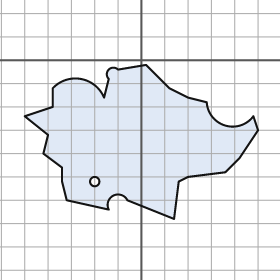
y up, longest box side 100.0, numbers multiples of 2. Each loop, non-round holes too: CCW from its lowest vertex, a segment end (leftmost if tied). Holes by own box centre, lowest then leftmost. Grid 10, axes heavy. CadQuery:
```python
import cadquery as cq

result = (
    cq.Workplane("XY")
    .moveTo(14.0, -68.0)
    .lineTo(16.0, -52.0)
    .lineTo(20.0, -50.0)
    .lineTo(36.0, -48.0)
    .lineTo(42.0, -42.0)
    .lineTo(50.0, -30.0)
    .lineTo(48.0, -24.0)
    .threePointArc((36.0, -28.0), (28.0, -18.0))
    .lineTo(20.0, -16.0)
    .lineTo(12.0, -12.0)
    .lineTo(2.0, -2.0)
    .lineTo(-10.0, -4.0)
    .threePointArc((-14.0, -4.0), (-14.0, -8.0))
    .lineTo(-16.0, -16.0)
    .threePointArc((-26.0, -8.0), (-38.0, -12.0))
    .lineTo(-38.0, -20.0)
    .lineTo(-50.0, -24.0)
    .lineTo(-40.0, -32.0)
    .lineTo(-42.0, -40.0)
    .lineTo(-34.0, -46.0)
    .lineTo(-34.0, -52.0)
    .lineTo(-32.0, -60.0)
    .lineTo(-14.0, -64.0)
    .threePointArc((-12.0, -58.0), (-6.0, -60.0))
    .close()
    .moveTo(-20.0, -52.0)
    .circle(2.0)
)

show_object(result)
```